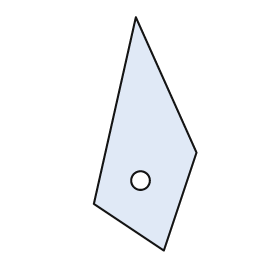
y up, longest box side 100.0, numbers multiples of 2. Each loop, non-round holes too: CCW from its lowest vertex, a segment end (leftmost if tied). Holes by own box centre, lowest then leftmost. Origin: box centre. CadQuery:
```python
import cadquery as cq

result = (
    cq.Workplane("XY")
    .moveTo(8.0, -50.0)
    .lineTo(22.0, -8.0)
    .lineTo(-4.0, 50.0)
    .lineTo(-22.0, -30.0)
    .close()
    .moveTo(-2.0, -20.0)
    .circle(4.0)
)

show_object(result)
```